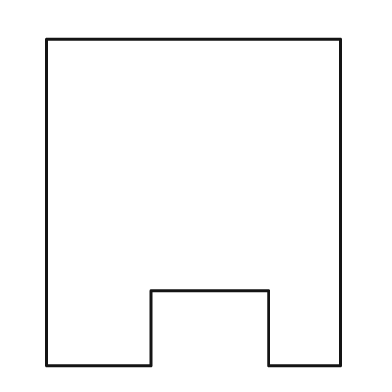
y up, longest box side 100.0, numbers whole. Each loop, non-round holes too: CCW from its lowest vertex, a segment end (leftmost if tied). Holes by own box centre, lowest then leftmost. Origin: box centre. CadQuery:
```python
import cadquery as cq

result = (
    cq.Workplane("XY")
    .moveTo(-45.0, -50.0)
    .lineTo(-13.0, -50.0)
    .lineTo(-13.0, -27.0)
    .lineTo(23.0, -27.0)
    .lineTo(23.0, -50.0)
    .lineTo(45.0, -50.0)
    .lineTo(45.0, 50.0)
    .lineTo(-45.0, 50.0)
    .close()
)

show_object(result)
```